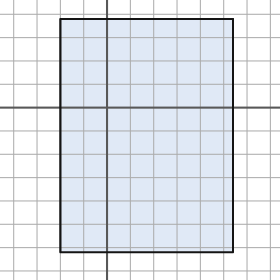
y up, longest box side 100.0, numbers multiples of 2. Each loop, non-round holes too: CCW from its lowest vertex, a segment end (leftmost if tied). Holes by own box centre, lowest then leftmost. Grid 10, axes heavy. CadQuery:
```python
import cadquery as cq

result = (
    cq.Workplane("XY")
    .moveTo(-20.0, -62.0)
    .lineTo(54.0, -62.0)
    .lineTo(54.0, 38.0)
    .lineTo(-20.0, 38.0)
    .close()
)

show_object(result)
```